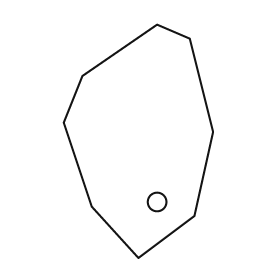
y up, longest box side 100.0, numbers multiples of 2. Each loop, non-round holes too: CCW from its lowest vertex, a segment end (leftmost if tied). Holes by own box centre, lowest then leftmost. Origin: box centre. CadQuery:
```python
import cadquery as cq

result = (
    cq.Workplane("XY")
    .moveTo(0.0, -50.0)
    .lineTo(24.0, -32.0)
    .lineTo(32.0, 4.0)
    .lineTo(22.0, 44.0)
    .lineTo(8.0, 50.0)
    .lineTo(-24.0, 28.0)
    .lineTo(-32.0, 8.0)
    .lineTo(-20.0, -28.0)
    .close()
    .moveTo(8.0, -26.0)
    .circle(4.0)
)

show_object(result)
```